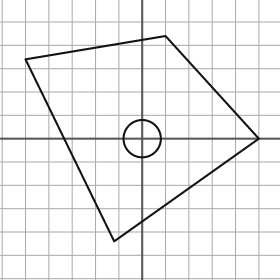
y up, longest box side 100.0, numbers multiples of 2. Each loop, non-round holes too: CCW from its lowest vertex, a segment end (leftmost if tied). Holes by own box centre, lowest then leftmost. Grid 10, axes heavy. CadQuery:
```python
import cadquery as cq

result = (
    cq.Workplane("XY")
    .moveTo(-12.0, -44.0)
    .lineTo(50.0, 0.0)
    .lineTo(10.0, 44.0)
    .lineTo(-50.0, 34.0)
    .close()
    .moveTo(0.0, 0.0)
    .circle(8.0)
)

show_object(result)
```